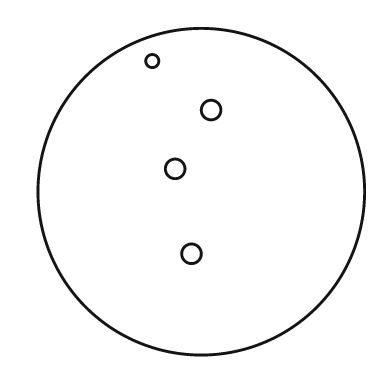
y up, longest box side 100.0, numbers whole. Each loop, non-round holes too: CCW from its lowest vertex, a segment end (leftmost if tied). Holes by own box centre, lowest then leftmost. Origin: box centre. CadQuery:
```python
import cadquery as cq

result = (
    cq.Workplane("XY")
    .moveTo(0.0, 0.0)
    .circle(50.0)
    .moveTo(-3.0, -19.0)
    .circle(3.0)
    .moveTo(-8.0, 7.0)
    .circle(3.0)
    .moveTo(3.0, 25.0)
    .circle(3.0)
    .moveTo(-15.0, 40.0)
    .circle(2.0)
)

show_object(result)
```